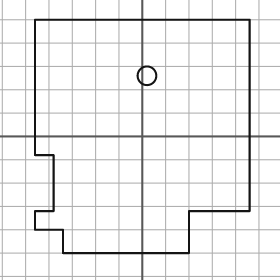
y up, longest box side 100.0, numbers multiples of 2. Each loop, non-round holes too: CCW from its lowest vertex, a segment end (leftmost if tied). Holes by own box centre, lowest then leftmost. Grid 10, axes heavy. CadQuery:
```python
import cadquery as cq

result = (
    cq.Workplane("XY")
    .moveTo(-34.0, -50.0)
    .lineTo(20.0, -50.0)
    .lineTo(20.0, -32.0)
    .lineTo(46.0, -32.0)
    .lineTo(46.0, 50.0)
    .lineTo(-46.0, 50.0)
    .lineTo(-46.0, -8.0)
    .lineTo(-38.0, -8.0)
    .lineTo(-38.0, -32.0)
    .lineTo(-46.0, -32.0)
    .lineTo(-46.0, -40.0)
    .lineTo(-34.0, -40.0)
    .close()
    .moveTo(2.0, 26.0)
    .circle(4.0)
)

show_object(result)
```